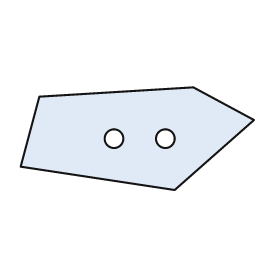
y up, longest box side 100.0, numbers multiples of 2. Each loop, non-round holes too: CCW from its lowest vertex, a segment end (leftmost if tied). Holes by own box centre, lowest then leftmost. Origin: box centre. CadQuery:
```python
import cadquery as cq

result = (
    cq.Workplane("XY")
    .moveTo(16.0, -22.0)
    .lineTo(50.0, 8.0)
    .lineTo(24.0, 22.0)
    .lineTo(-42.0, 18.0)
    .lineTo(-50.0, -12.0)
    .close()
    .moveTo(-10.0, 0.0)
    .circle(4.0)
    .moveTo(12.0, 0.0)
    .circle(4.0)
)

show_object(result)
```